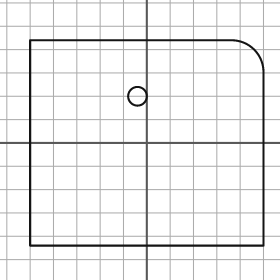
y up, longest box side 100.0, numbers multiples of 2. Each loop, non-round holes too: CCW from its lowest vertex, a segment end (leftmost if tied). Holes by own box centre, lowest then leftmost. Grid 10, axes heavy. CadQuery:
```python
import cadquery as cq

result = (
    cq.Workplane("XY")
    .moveTo(-50.0, -44.0)
    .lineTo(50.0, -44.0)
    .lineTo(50.0, 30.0)
    .threePointArc((46.0, 40.0), (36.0, 44.0))
    .lineTo(-50.0, 44.0)
    .close()
    .moveTo(-4.0, 20.0)
    .circle(4.0)
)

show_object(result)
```